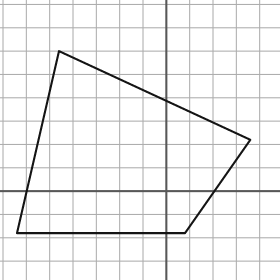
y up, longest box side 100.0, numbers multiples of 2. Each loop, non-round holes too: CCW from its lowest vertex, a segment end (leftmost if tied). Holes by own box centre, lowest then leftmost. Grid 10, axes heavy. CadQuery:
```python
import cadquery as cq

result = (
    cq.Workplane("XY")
    .moveTo(-64.0, -18.0)
    .lineTo(8.0, -18.0)
    .lineTo(36.0, 22.0)
    .lineTo(-46.0, 60.0)
    .close()
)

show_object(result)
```